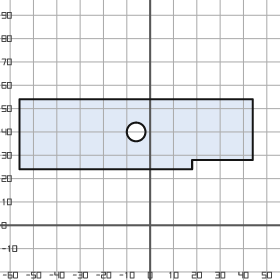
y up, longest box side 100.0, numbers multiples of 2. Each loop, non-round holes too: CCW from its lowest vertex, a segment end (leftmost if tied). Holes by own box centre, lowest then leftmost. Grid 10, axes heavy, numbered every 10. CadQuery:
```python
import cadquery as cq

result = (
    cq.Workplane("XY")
    .moveTo(-56.0, 24.0)
    .lineTo(18.0, 24.0)
    .lineTo(18.0, 28.0)
    .lineTo(44.0, 28.0)
    .lineTo(44.0, 54.0)
    .lineTo(-56.0, 54.0)
    .close()
    .moveTo(-6.0, 40.0)
    .circle(4.0)
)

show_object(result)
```